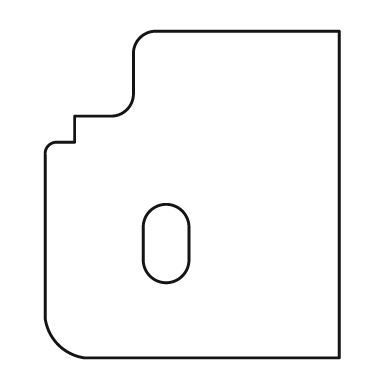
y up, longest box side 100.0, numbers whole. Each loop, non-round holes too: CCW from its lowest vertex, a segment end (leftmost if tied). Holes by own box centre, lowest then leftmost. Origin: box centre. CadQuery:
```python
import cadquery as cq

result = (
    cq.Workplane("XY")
    .moveTo(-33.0, -50.0)
    .lineTo(45.0, -50.0)
    .lineTo(45.0, 50.0)
    .lineTo(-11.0, 50.0)
    .threePointArc((-16.0, 48.0), (-18.0, 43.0))
    .lineTo(-18.0, 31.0)
    .threePointArc((-20.0, 26.0), (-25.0, 24.0))
    .lineTo(-36.0, 24.0)
    .lineTo(-36.0, 16.0)
    .lineTo(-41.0, 16.0)
    .threePointArc((-44.0, 15.0), (-45.0, 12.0))
    .lineTo(-45.0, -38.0)
    .threePointArc((-41.0, -46.0), (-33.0, -50.0))
    .close()
    .moveTo(-15.0, -20.0)
    .threePointArc((-8.0, -27.0), (-1.0, -20.0))
    .lineTo(-1.0, -10.0)
    .threePointArc((-8.0, -3.0), (-15.0, -10.0))
    .close()
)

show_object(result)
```